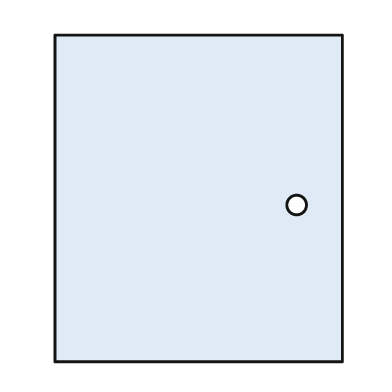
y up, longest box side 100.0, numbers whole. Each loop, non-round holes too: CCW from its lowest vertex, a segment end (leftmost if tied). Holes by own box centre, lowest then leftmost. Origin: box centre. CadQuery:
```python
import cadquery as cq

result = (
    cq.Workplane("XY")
    .moveTo(-44.0, -50.0)
    .lineTo(44.0, -50.0)
    .lineTo(44.0, 50.0)
    .lineTo(-44.0, 50.0)
    .close()
    .moveTo(30.0, -2.0)
    .circle(3.0)
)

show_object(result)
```